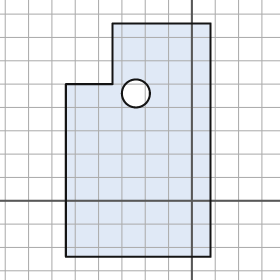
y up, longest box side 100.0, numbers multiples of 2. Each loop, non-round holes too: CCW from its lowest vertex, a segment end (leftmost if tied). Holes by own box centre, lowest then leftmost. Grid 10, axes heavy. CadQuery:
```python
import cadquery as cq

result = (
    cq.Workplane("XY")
    .moveTo(-54.0, -24.0)
    .lineTo(8.0, -24.0)
    .lineTo(8.0, 76.0)
    .lineTo(-34.0, 76.0)
    .lineTo(-34.0, 50.0)
    .lineTo(-54.0, 50.0)
    .close()
    .moveTo(-24.0, 46.0)
    .circle(6.0)
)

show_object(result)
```